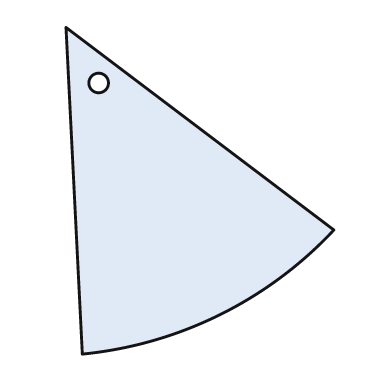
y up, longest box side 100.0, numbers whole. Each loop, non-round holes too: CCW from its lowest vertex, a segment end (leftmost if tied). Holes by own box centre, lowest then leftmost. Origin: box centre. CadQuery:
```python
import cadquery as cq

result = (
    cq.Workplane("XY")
    .moveTo(-36.0, -50.0)
    .threePointArc((6.0, -38.0), (41.0, -12.0))
    .lineTo(-41.0, 50.0)
    .close()
    .moveTo(-31.0, 33.0)
    .circle(3.0)
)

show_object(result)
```